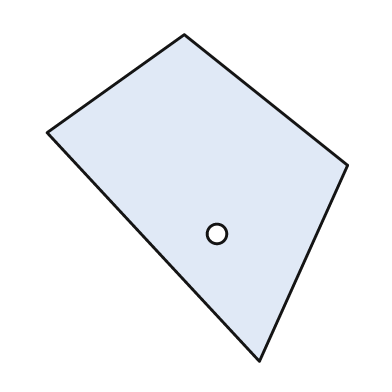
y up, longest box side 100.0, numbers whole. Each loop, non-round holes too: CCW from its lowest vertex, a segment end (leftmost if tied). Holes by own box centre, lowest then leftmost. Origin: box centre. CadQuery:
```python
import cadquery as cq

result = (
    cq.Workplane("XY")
    .moveTo(19.0, -50.0)
    .lineTo(46.0, 10.0)
    .lineTo(-4.0, 50.0)
    .lineTo(-46.0, 20.0)
    .close()
    .moveTo(6.0, -11.0)
    .circle(3.0)
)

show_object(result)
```